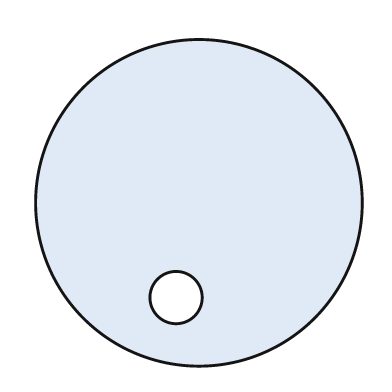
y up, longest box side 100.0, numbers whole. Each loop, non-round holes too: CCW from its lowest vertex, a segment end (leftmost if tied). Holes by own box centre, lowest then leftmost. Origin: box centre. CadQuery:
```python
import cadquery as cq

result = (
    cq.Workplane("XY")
    .moveTo(0.0, 0.0)
    .circle(50.0)
    .moveTo(-7.0, -29.0)
    .circle(8.0)
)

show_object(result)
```